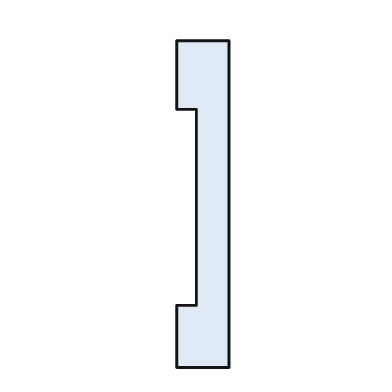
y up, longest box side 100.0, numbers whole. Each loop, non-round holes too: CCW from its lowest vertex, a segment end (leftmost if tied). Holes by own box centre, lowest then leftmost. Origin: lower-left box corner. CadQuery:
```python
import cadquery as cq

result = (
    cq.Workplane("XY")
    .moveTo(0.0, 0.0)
    .lineTo(16.0, 0.0)
    .lineTo(16.0, 100.0)
    .lineTo(0.0, 100.0)
    .lineTo(0.0, 79.0)
    .lineTo(6.0, 79.0)
    .lineTo(6.0, 19.0)
    .lineTo(0.0, 19.0)
    .close()
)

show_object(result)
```